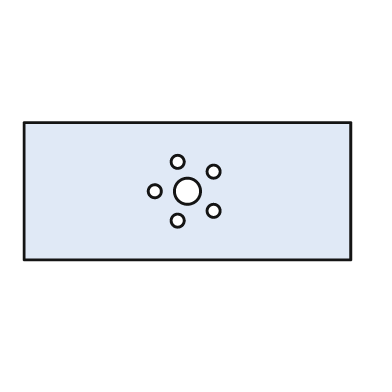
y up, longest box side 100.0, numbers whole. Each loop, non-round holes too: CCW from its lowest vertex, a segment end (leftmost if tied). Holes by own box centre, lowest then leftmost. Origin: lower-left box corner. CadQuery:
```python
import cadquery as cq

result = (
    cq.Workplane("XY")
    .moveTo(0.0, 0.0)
    .lineTo(100.0, 0.0)
    .lineTo(100.0, 42.0)
    .lineTo(0.0, 42.0)
    .close()
    .moveTo(47.0, 12.0)
    .circle(2.0)
    .moveTo(58.0, 15.0)
    .circle(2.0)
    .moveTo(40.0, 21.0)
    .circle(2.0)
    .moveTo(50.0, 21.0)
    .circle(4.0)
    .moveTo(58.0, 27.0)
    .circle(2.0)
    .moveTo(47.0, 30.0)
    .circle(2.0)
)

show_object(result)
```